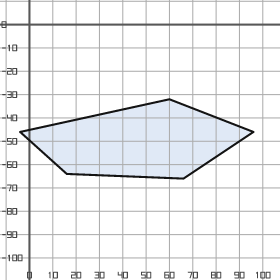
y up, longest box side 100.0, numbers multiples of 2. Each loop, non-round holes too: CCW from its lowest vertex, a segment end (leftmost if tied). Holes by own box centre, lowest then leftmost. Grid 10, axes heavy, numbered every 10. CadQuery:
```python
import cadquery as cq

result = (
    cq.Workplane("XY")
    .moveTo(66.0, -66.0)
    .lineTo(96.0, -46.0)
    .lineTo(60.0, -32.0)
    .lineTo(-4.0, -46.0)
    .lineTo(16.0, -64.0)
    .close()
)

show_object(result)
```